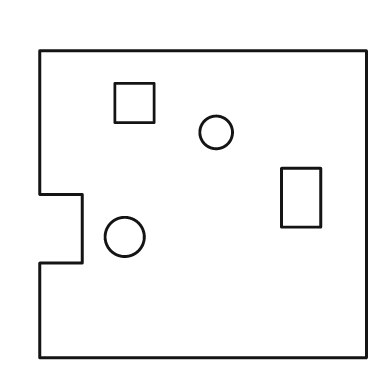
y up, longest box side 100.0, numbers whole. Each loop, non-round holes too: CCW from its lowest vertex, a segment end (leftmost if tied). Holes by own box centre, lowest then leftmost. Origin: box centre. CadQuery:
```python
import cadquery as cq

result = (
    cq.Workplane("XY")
    .moveTo(-50.0, -47.0)
    .lineTo(50.0, -47.0)
    .lineTo(50.0, 47.0)
    .lineTo(-50.0, 47.0)
    .lineTo(-50.0, 3.0)
    .lineTo(-37.0, 3.0)
    .lineTo(-37.0, -18.0)
    .lineTo(-50.0, -18.0)
    .close()
    .moveTo(-24.0, -10.0)
    .circle(6.0)
    .moveTo(24.0, -7.0)
    .lineTo(36.0, -7.0)
    .lineTo(36.0, 11.0)
    .lineTo(24.0, 11.0)
    .close()
    .moveTo(4.0, 22.0)
    .circle(5.0)
    .moveTo(-27.0, 25.0)
    .lineTo(-15.0, 25.0)
    .lineTo(-15.0, 37.0)
    .lineTo(-27.0, 37.0)
    .close()
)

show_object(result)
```